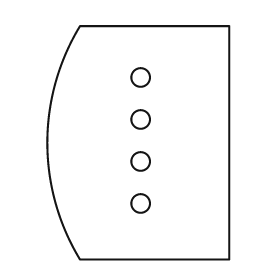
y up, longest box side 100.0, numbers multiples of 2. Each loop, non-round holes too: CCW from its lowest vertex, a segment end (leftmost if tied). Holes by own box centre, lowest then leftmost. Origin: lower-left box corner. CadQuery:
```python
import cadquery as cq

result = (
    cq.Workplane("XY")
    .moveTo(14.0, 0.0)
    .lineTo(78.0, 0.0)
    .lineTo(78.0, 100.0)
    .lineTo(14.0, 100.0)
    .threePointArc((0.0, 50.0), (14.0, 0.0))
    .close()
    .moveTo(40.0, 24.0)
    .circle(4.0)
    .moveTo(40.0, 42.0)
    .circle(4.0)
    .moveTo(40.0, 60.0)
    .circle(4.0)
    .moveTo(40.0, 78.0)
    .circle(4.0)
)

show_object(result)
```